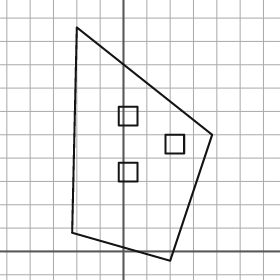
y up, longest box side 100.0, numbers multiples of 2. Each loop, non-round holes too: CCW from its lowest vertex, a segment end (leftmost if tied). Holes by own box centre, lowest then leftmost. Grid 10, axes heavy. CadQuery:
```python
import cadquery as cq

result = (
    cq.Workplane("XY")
    .moveTo(20.0, -4.0)
    .lineTo(38.0, 50.0)
    .lineTo(-20.0, 96.0)
    .lineTo(-22.0, 8.0)
    .close()
    .moveTo(-2.0, 30.0)
    .lineTo(6.0, 30.0)
    .lineTo(6.0, 38.0)
    .lineTo(-2.0, 38.0)
    .close()
    .moveTo(18.0, 42.0)
    .lineTo(26.0, 42.0)
    .lineTo(26.0, 50.0)
    .lineTo(18.0, 50.0)
    .close()
    .moveTo(-2.0, 54.0)
    .lineTo(6.0, 54.0)
    .lineTo(6.0, 62.0)
    .lineTo(-2.0, 62.0)
    .close()
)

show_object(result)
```